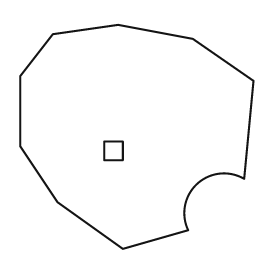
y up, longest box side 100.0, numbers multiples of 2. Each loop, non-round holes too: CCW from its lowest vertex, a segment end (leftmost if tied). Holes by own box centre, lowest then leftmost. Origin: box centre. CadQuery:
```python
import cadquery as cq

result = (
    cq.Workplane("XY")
    .moveTo(-6.0, -48.0)
    .lineTo(22.0, -40.0)
    .threePointArc((26.0, -20.0), (46.0, -18.0))
    .lineTo(50.0, 24.0)
    .lineTo(24.0, 42.0)
    .lineTo(-8.0, 48.0)
    .lineTo(-36.0, 44.0)
    .lineTo(-50.0, 26.0)
    .lineTo(-50.0, -4.0)
    .lineTo(-34.0, -28.0)
    .close()
    .moveTo(-14.0, -10.0)
    .lineTo(-6.0, -10.0)
    .lineTo(-6.0, -2.0)
    .lineTo(-14.0, -2.0)
    .close()
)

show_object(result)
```